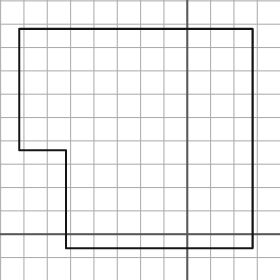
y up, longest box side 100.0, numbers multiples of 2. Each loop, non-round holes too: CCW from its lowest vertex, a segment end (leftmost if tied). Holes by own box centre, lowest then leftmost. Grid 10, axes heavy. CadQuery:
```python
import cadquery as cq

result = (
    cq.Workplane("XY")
    .moveTo(-52.0, -6.0)
    .lineTo(28.0, -6.0)
    .lineTo(28.0, 88.0)
    .lineTo(-72.0, 88.0)
    .lineTo(-72.0, 36.0)
    .lineTo(-52.0, 36.0)
    .close()
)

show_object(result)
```